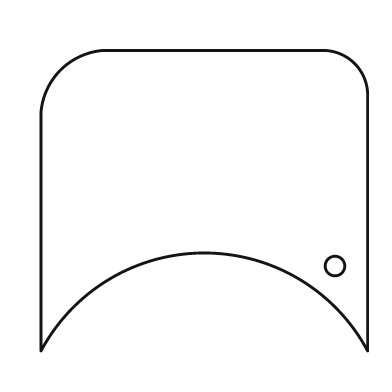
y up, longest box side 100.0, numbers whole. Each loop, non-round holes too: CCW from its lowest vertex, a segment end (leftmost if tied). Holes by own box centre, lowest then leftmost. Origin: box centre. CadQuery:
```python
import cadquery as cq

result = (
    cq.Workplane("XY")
    .moveTo(-50.0, -46.0)
    .threePointArc((0.0, -16.0), (50.0, -46.0))
    .lineTo(50.0, 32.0)
    .threePointArc((46.0, 42.0), (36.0, 46.0))
    .lineTo(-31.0, 46.0)
    .threePointArc((-44.0, 40.0), (-50.0, 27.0))
    .close()
    .moveTo(40.0, -20.0)
    .circle(3.0)
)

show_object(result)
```